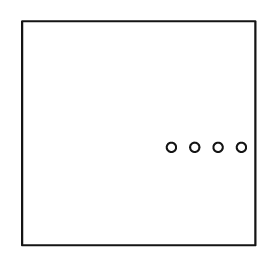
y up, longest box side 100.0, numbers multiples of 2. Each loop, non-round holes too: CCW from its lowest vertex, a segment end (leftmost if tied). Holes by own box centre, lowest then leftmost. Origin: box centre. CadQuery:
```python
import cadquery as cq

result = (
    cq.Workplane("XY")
    .moveTo(-50.0, -48.0)
    .lineTo(50.0, -48.0)
    .lineTo(50.0, 48.0)
    .lineTo(-50.0, 48.0)
    .close()
    .moveTo(14.0, -6.0)
    .circle(2.0)
    .moveTo(24.0, -6.0)
    .circle(2.0)
    .moveTo(34.0, -6.0)
    .circle(2.0)
    .moveTo(44.0, -6.0)
    .circle(2.0)
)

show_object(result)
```